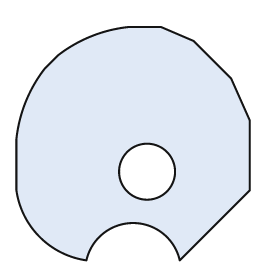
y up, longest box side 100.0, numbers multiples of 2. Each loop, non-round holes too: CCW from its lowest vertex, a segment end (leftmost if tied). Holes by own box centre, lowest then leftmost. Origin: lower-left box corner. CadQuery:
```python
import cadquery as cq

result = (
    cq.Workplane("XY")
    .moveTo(30.0, 0.0)
    .threePointArc((50.0, 16.0), (70.0, 0.0))
    .lineTo(100.0, 30.0)
    .lineTo(100.0, 60.0)
    .lineTo(92.0, 78.0)
    .lineTo(76.0, 94.0)
    .lineTo(62.0, 100.0)
    .lineTo(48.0, 100.0)
    .threePointArc((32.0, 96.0), (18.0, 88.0))
    .lineTo(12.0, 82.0)
    .threePointArc((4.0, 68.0), (0.0, 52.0))
    .lineTo(0.0, 30.0)
    .threePointArc((10.0, 10.0), (30.0, 0.0))
    .close()
    .moveTo(56.0, 38.0)
    .circle(12.0)
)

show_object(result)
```